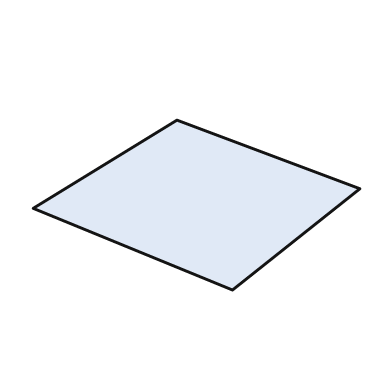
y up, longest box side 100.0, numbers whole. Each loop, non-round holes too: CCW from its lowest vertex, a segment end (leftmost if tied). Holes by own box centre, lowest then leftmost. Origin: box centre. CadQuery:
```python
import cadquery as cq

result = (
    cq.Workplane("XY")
    .moveTo(11.0, -26.0)
    .lineTo(50.0, 5.0)
    .lineTo(-6.0, 26.0)
    .lineTo(-50.0, -1.0)
    .close()
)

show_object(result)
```